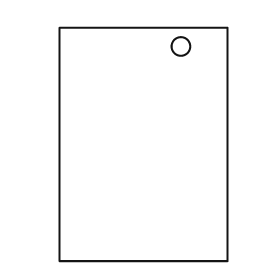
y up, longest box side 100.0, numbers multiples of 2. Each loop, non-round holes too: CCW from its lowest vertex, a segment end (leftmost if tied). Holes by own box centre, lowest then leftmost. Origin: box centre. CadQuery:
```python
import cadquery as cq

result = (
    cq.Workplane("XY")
    .moveTo(-36.0, -50.0)
    .lineTo(36.0, -50.0)
    .lineTo(36.0, 50.0)
    .lineTo(-36.0, 50.0)
    .close()
    .moveTo(16.0, 42.0)
    .circle(4.0)
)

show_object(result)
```